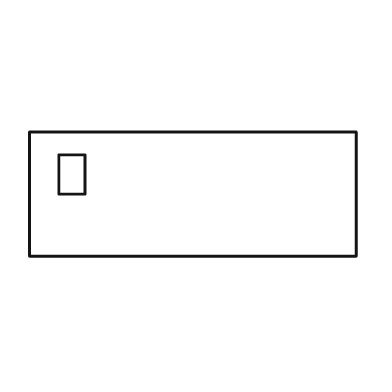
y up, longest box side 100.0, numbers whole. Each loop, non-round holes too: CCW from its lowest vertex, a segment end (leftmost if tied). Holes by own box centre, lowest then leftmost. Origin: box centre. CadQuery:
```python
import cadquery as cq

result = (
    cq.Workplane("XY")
    .moveTo(-50.0, -19.0)
    .lineTo(50.0, -19.0)
    .lineTo(50.0, 19.0)
    .lineTo(-50.0, 19.0)
    .close()
    .moveTo(-41.0, 0.0)
    .lineTo(-33.0, 0.0)
    .lineTo(-33.0, 12.0)
    .lineTo(-41.0, 12.0)
    .close()
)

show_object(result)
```